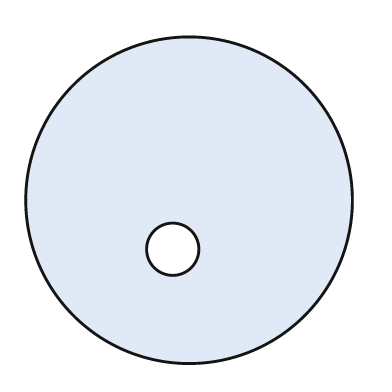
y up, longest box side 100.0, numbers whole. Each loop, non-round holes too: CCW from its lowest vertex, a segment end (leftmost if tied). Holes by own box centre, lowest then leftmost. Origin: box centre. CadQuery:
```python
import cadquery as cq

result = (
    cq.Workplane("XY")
    .moveTo(0.0, 0.0)
    .circle(50.0)
    .moveTo(-5.0, -15.0)
    .circle(8.0)
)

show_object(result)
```